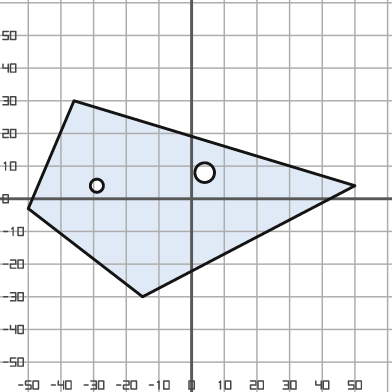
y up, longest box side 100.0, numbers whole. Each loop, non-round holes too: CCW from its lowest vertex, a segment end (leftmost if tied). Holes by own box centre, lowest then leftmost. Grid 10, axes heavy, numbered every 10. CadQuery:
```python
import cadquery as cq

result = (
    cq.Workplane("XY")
    .moveTo(-15.0, -30.0)
    .lineTo(50.0, 4.0)
    .lineTo(-36.0, 30.0)
    .lineTo(-50.0, -3.0)
    .close()
    .moveTo(-29.0, 4.0)
    .circle(2.0)
    .moveTo(4.0, 8.0)
    .circle(3.0)
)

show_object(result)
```